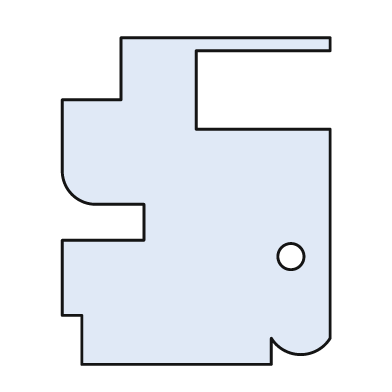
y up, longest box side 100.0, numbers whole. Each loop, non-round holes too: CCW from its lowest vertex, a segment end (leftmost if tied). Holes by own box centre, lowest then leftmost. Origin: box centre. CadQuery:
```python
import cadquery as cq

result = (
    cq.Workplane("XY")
    .moveTo(-35.0, -50.0)
    .lineTo(23.0, -50.0)
    .lineTo(23.0, -42.0)
    .threePointArc((32.0, -47.0), (41.0, -42.0))
    .lineTo(41.0, 22.0)
    .lineTo(0.0, 22.0)
    .lineTo(0.0, 46.0)
    .lineTo(41.0, 46.0)
    .lineTo(41.0, 50.0)
    .lineTo(-23.0, 50.0)
    .lineTo(-23.0, 31.0)
    .lineTo(-41.0, 31.0)
    .lineTo(-41.0, 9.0)
    .threePointArc((-38.0, 2.0), (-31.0, -1.0))
    .lineTo(-16.0, -1.0)
    .lineTo(-16.0, -12.0)
    .lineTo(-41.0, -12.0)
    .lineTo(-41.0, -35.0)
    .lineTo(-35.0, -35.0)
    .close()
    .moveTo(29.0, -17.0)
    .circle(4.0)
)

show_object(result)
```